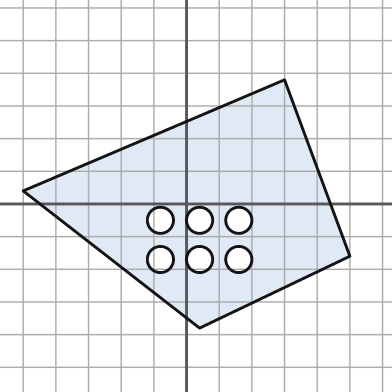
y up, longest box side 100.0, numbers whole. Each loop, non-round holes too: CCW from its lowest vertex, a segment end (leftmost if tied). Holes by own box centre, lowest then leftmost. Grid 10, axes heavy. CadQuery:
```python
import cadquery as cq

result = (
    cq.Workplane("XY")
    .moveTo(4.0, -38.0)
    .lineTo(50.0, -16.0)
    .lineTo(30.0, 38.0)
    .lineTo(-50.0, 4.0)
    .close()
    .moveTo(-8.0, -17.0)
    .circle(4.0)
    .moveTo(4.0, -17.0)
    .circle(4.0)
    .moveTo(16.0, -17.0)
    .circle(4.0)
    .moveTo(-8.0, -5.0)
    .circle(4.0)
    .moveTo(4.0, -5.0)
    .circle(4.0)
    .moveTo(16.0, -5.0)
    .circle(4.0)
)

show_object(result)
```